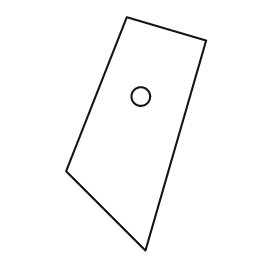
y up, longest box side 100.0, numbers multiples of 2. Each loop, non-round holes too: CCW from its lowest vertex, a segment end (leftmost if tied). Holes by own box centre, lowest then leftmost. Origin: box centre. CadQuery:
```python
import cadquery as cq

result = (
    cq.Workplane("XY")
    .moveTo(4.0, -50.0)
    .lineTo(30.0, 40.0)
    .lineTo(-4.0, 50.0)
    .lineTo(-30.0, -16.0)
    .close()
    .moveTo(2.0, 16.0)
    .circle(4.0)
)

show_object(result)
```